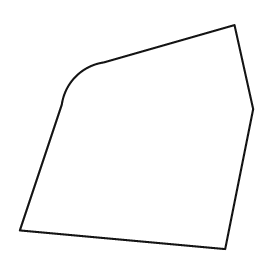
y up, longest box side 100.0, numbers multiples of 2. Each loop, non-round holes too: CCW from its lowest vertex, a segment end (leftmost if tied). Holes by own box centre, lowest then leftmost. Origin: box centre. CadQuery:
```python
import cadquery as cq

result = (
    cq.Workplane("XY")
    .moveTo(38.0, -48.0)
    .lineTo(50.0, 12.0)
    .lineTo(42.0, 48.0)
    .lineTo(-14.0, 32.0)
    .threePointArc((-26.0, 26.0), (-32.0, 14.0))
    .lineTo(-50.0, -40.0)
    .close()
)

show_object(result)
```